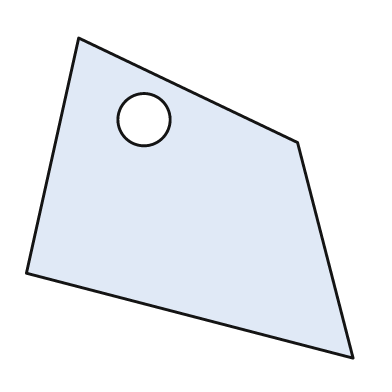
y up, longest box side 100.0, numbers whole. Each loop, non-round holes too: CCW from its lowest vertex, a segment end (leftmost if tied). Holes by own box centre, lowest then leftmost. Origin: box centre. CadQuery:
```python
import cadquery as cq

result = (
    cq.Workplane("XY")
    .moveTo(50.0, -49.0)
    .lineTo(33.0, 17.0)
    .lineTo(-34.0, 49.0)
    .lineTo(-50.0, -23.0)
    .close()
    .moveTo(-14.0, 24.0)
    .circle(8.0)
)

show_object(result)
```